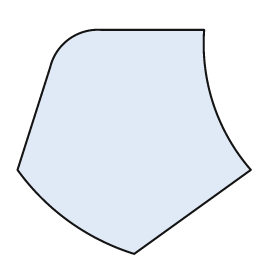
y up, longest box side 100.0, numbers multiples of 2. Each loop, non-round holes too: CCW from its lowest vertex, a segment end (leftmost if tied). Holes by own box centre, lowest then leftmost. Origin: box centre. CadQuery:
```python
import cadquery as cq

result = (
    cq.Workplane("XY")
    .moveTo(0.0, -48.0)
    .lineTo(50.0, -12.0)
    .threePointArc((34.0, 16.0), (30.0, 48.0))
    .lineTo(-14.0, 48.0)
    .threePointArc((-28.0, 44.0), (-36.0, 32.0))
    .lineTo(-50.0, -12.0)
    .threePointArc((-28.0, -34.0), (0.0, -48.0))
    .close()
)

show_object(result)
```